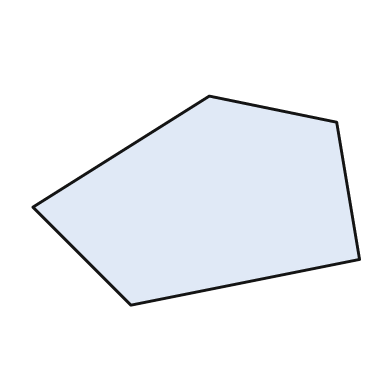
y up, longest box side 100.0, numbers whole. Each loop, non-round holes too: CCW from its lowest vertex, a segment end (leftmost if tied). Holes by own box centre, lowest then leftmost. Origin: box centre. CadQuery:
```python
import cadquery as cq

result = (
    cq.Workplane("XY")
    .moveTo(-20.0, -32.0)
    .lineTo(50.0, -18.0)
    .lineTo(43.0, 24.0)
    .lineTo(4.0, 32.0)
    .lineTo(-50.0, -2.0)
    .close()
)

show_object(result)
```